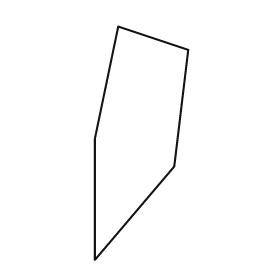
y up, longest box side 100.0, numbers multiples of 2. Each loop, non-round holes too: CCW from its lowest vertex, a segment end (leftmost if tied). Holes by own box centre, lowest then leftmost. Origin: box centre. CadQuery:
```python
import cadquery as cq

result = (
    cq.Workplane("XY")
    .moveTo(-20.0, -50.0)
    .lineTo(14.0, -10.0)
    .lineTo(20.0, 40.0)
    .lineTo(-10.0, 50.0)
    .lineTo(-20.0, 2.0)
    .close()
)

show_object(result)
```